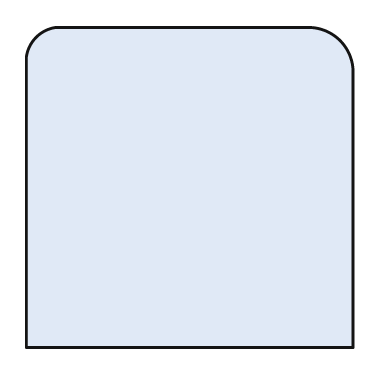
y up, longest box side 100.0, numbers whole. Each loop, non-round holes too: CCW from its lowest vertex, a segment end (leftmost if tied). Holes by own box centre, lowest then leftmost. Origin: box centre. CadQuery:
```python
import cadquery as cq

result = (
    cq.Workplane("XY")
    .moveTo(-50.0, -49.0)
    .lineTo(50.0, -49.0)
    .lineTo(50.0, 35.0)
    .threePointArc((46.0, 45.0), (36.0, 49.0))
    .lineTo(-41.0, 49.0)
    .threePointArc((-47.0, 46.0), (-50.0, 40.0))
    .close()
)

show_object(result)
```